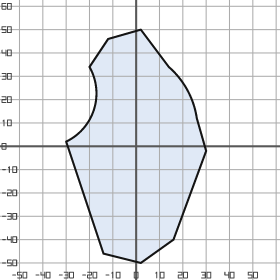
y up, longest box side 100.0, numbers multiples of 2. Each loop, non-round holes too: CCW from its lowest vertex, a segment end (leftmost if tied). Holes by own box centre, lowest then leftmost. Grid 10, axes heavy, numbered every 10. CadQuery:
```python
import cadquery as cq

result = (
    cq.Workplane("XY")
    .moveTo(2.0, -50.0)
    .lineTo(16.0, -40.0)
    .lineTo(30.0, -2.0)
    .lineTo(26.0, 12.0)
    .threePointArc((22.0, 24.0), (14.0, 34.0))
    .lineTo(2.0, 50.0)
    .lineTo(-12.0, 46.0)
    .lineTo(-20.0, 34.0)
    .threePointArc((-18.0, 16.0), (-30.0, 2.0))
    .lineTo(-14.0, -46.0)
    .close()
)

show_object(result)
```